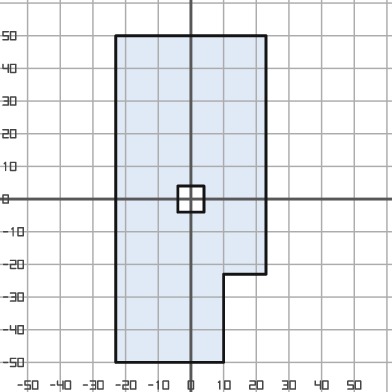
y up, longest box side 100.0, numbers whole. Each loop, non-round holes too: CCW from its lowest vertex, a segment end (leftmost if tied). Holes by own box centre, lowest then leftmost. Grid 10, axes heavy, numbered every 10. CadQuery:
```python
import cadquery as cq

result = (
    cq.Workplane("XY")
    .moveTo(-23.0, -50.0)
    .lineTo(10.0, -50.0)
    .lineTo(10.0, -23.0)
    .lineTo(23.0, -23.0)
    .lineTo(23.0, 50.0)
    .lineTo(-23.0, 50.0)
    .close()
    .moveTo(-4.0, -4.0)
    .lineTo(4.0, -4.0)
    .lineTo(4.0, 4.0)
    .lineTo(-4.0, 4.0)
    .close()
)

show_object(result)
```